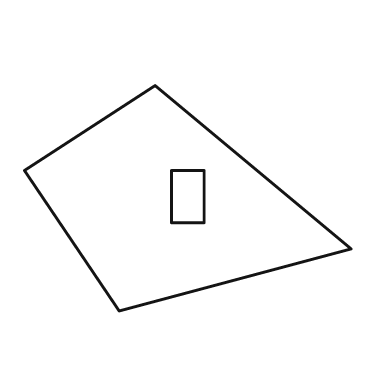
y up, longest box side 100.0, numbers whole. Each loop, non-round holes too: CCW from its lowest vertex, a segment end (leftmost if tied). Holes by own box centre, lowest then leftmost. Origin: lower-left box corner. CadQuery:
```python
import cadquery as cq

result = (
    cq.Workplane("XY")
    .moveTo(29.0, 0.0)
    .lineTo(100.0, 19.0)
    .lineTo(40.0, 69.0)
    .lineTo(0.0, 43.0)
    .close()
    .moveTo(45.0, 27.0)
    .lineTo(55.0, 27.0)
    .lineTo(55.0, 43.0)
    .lineTo(45.0, 43.0)
    .close()
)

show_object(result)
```